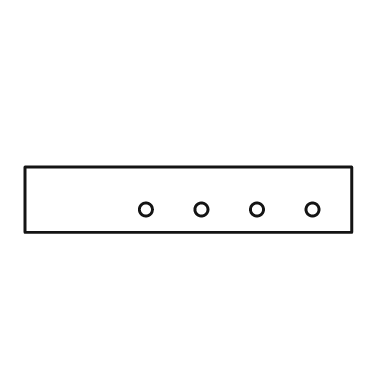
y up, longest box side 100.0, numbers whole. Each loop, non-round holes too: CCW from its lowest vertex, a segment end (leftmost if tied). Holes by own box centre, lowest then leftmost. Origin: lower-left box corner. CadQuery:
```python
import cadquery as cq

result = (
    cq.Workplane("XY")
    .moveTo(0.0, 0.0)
    .lineTo(100.0, 0.0)
    .lineTo(100.0, 20.0)
    .lineTo(0.0, 20.0)
    .close()
    .moveTo(37.0, 7.0)
    .circle(2.0)
    .moveTo(54.0, 7.0)
    .circle(2.0)
    .moveTo(71.0, 7.0)
    .circle(2.0)
    .moveTo(88.0, 7.0)
    .circle(2.0)
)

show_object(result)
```